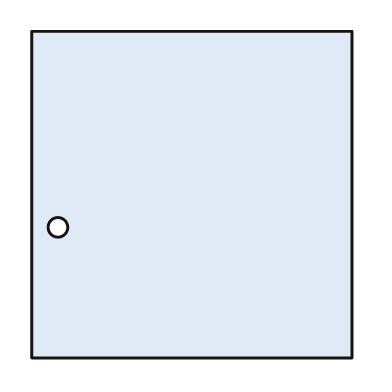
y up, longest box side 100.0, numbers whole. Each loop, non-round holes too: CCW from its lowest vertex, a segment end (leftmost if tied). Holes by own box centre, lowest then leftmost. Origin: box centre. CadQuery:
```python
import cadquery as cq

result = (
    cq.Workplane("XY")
    .moveTo(-49.0, -50.0)
    .lineTo(49.0, -50.0)
    .lineTo(49.0, 50.0)
    .lineTo(-49.0, 50.0)
    .close()
    .moveTo(-41.0, -10.0)
    .circle(3.0)
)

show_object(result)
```